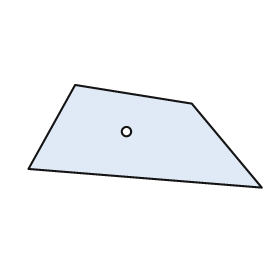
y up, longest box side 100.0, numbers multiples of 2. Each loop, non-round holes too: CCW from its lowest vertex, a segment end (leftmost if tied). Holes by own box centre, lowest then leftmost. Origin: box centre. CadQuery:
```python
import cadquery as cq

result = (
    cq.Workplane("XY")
    .moveTo(50.0, -22.0)
    .lineTo(20.0, 14.0)
    .lineTo(-30.0, 22.0)
    .lineTo(-50.0, -14.0)
    .close()
    .moveTo(-8.0, 2.0)
    .circle(2.0)
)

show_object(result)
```